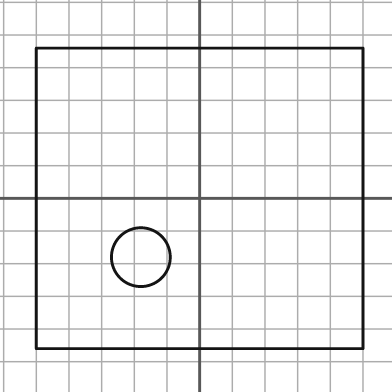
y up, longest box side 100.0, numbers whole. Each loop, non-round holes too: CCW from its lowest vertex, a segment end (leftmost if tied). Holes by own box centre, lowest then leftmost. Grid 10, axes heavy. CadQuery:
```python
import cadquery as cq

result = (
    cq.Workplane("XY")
    .moveTo(-50.0, -46.0)
    .lineTo(50.0, -46.0)
    .lineTo(50.0, 46.0)
    .lineTo(-50.0, 46.0)
    .close()
    .moveTo(-18.0, -18.0)
    .circle(9.0)
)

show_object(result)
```